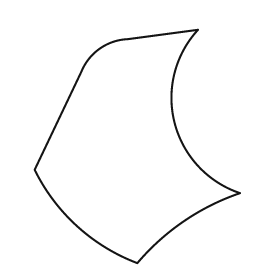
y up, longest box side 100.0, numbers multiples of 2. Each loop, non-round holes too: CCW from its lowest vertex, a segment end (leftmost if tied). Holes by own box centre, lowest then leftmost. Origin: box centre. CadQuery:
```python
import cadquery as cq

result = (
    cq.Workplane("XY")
    .moveTo(0.0, -50.0)
    .threePointArc((20.0, -32.0), (44.0, -20.0))
    .threePointArc((16.0, 10.0), (26.0, 50.0))
    .lineTo(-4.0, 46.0)
    .threePointArc((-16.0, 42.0), (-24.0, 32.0))
    .lineTo(-44.0, -10.0)
    .threePointArc((-26.0, -34.0), (0.0, -50.0))
    .close()
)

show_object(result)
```